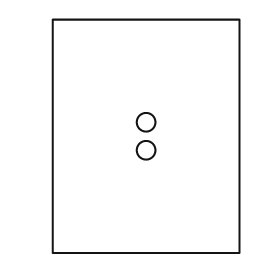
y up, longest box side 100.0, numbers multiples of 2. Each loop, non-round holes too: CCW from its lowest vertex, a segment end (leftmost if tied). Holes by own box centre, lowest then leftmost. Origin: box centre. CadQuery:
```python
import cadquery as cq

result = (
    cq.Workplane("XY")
    .moveTo(-40.0, -50.0)
    .lineTo(40.0, -50.0)
    .lineTo(40.0, 50.0)
    .lineTo(-40.0, 50.0)
    .close()
    .moveTo(0.0, -6.0)
    .circle(4.0)
    .moveTo(0.0, 6.0)
    .circle(4.0)
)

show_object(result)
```